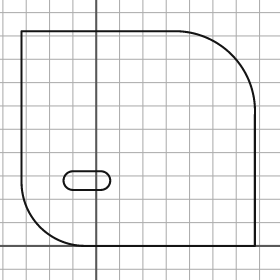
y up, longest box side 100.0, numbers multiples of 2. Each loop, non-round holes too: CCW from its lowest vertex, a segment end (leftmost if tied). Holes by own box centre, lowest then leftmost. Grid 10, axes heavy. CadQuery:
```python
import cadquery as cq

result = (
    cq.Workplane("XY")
    .moveTo(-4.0, 0.0)
    .lineTo(68.0, 0.0)
    .lineTo(68.0, 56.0)
    .threePointArc((58.0, 82.0), (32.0, 92.0))
    .lineTo(-32.0, 92.0)
    .lineTo(-32.0, 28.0)
    .threePointArc((-24.0, 8.0), (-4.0, 0.0))
    .close()
    .moveTo(-10.0, 24.0)
    .lineTo(2.0, 24.0)
    .threePointArc((6.0, 28.0), (2.0, 32.0))
    .lineTo(-10.0, 32.0)
    .threePointArc((-14.0, 28.0), (-10.0, 24.0))
    .close()
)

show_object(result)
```